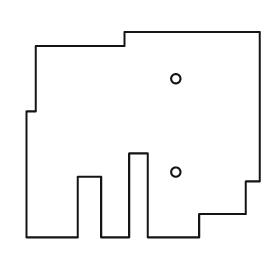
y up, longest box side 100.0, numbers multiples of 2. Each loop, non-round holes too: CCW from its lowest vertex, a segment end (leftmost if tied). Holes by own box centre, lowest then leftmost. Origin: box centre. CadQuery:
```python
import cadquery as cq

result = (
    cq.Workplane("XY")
    .moveTo(-50.0, -44.0)
    .lineTo(-28.0, -44.0)
    .lineTo(-28.0, -18.0)
    .lineTo(-18.0, -18.0)
    .lineTo(-18.0, -44.0)
    .lineTo(-6.0, -44.0)
    .lineTo(-6.0, -8.0)
    .lineTo(2.0, -8.0)
    .lineTo(2.0, -44.0)
    .lineTo(24.0, -44.0)
    .lineTo(24.0, -34.0)
    .lineTo(44.0, -34.0)
    .lineTo(44.0, -20.0)
    .lineTo(50.0, -20.0)
    .lineTo(50.0, 44.0)
    .lineTo(-8.0, 44.0)
    .lineTo(-8.0, 38.0)
    .lineTo(-46.0, 38.0)
    .lineTo(-46.0, 10.0)
    .lineTo(-50.0, 10.0)
    .close()
    .moveTo(14.0, -16.0)
    .circle(2.0)
    .moveTo(14.0, 24.0)
    .circle(2.0)
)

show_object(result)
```